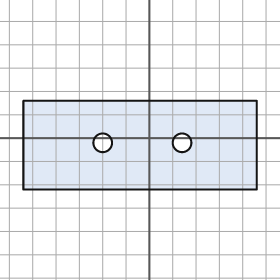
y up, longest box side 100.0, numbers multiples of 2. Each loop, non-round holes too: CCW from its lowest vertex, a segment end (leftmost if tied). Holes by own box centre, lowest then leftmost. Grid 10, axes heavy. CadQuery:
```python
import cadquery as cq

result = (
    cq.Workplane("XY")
    .moveTo(-54.0, -22.0)
    .lineTo(46.0, -22.0)
    .lineTo(46.0, 16.0)
    .lineTo(-54.0, 16.0)
    .close()
    .moveTo(-20.0, -2.0)
    .circle(4.0)
    .moveTo(14.0, -2.0)
    .circle(4.0)
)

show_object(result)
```